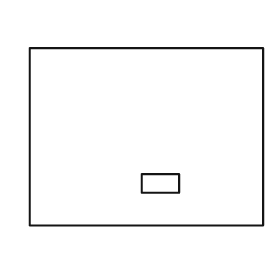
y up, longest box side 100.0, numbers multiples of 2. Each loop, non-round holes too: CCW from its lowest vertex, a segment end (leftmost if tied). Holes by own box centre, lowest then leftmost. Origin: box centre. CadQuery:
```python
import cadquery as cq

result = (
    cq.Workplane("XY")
    .moveTo(-50.0, -38.0)
    .lineTo(50.0, -38.0)
    .lineTo(50.0, 38.0)
    .lineTo(-50.0, 38.0)
    .close()
    .moveTo(-2.0, -24.0)
    .lineTo(14.0, -24.0)
    .lineTo(14.0, -16.0)
    .lineTo(-2.0, -16.0)
    .close()
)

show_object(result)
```